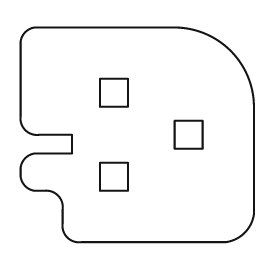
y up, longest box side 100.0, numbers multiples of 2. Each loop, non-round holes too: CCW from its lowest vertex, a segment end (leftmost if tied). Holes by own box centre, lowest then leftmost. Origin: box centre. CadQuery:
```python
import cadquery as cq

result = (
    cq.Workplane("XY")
    .moveTo(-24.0, -46.0)
    .lineTo(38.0, -46.0)
    .threePointArc((46.0, -42.0), (50.0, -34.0))
    .lineTo(50.0, 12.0)
    .threePointArc((40.0, 36.0), (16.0, 46.0))
    .lineTo(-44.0, 46.0)
    .threePointArc((-48.0, 44.0), (-50.0, 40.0))
    .lineTo(-50.0, 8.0)
    .threePointArc((-48.0, 2.0), (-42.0, 0.0))
    .lineTo(-28.0, 0.0)
    .lineTo(-28.0, -8.0)
    .lineTo(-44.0, -8.0)
    .threePointArc((-48.0, -10.0), (-50.0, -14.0))
    .lineTo(-50.0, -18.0)
    .threePointArc((-48.0, -22.0), (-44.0, -24.0))
    .lineTo(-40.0, -24.0)
    .threePointArc((-34.0, -26.0), (-32.0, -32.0))
    .lineTo(-32.0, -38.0)
    .threePointArc((-30.0, -44.0), (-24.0, -46.0))
    .close()
    .moveTo(-16.0, -24.0)
    .lineTo(-4.0, -24.0)
    .lineTo(-4.0, -12.0)
    .lineTo(-16.0, -12.0)
    .close()
    .moveTo(16.0, -6.0)
    .lineTo(28.0, -6.0)
    .lineTo(28.0, 6.0)
    .lineTo(16.0, 6.0)
    .close()
    .moveTo(-16.0, 12.0)
    .lineTo(-4.0, 12.0)
    .lineTo(-4.0, 24.0)
    .lineTo(-16.0, 24.0)
    .close()
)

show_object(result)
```